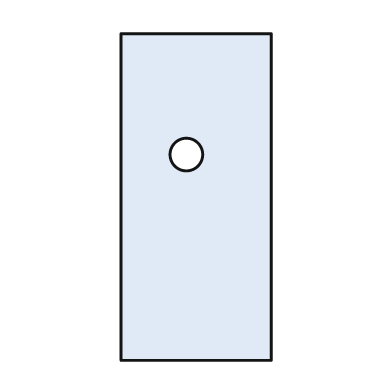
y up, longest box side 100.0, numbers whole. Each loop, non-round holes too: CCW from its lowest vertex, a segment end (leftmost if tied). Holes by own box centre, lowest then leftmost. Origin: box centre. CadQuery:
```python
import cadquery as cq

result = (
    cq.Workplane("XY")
    .moveTo(-23.0, -50.0)
    .lineTo(23.0, -50.0)
    .lineTo(23.0, 50.0)
    .lineTo(-23.0, 50.0)
    .close()
    .moveTo(-3.0, 13.0)
    .circle(5.0)
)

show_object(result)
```